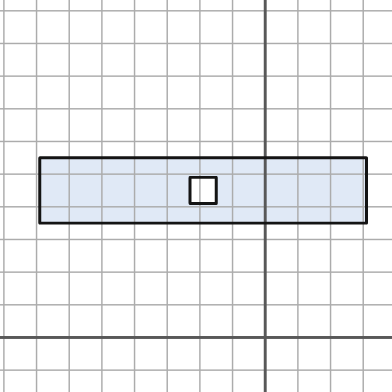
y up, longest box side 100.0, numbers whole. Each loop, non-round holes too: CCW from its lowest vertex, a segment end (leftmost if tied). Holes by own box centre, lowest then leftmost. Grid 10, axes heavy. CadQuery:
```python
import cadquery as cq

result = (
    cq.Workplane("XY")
    .moveTo(-69.0, 35.0)
    .lineTo(31.0, 35.0)
    .lineTo(31.0, 55.0)
    .lineTo(-69.0, 55.0)
    .close()
    .moveTo(-23.0, 41.0)
    .lineTo(-15.0, 41.0)
    .lineTo(-15.0, 49.0)
    .lineTo(-23.0, 49.0)
    .close()
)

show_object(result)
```